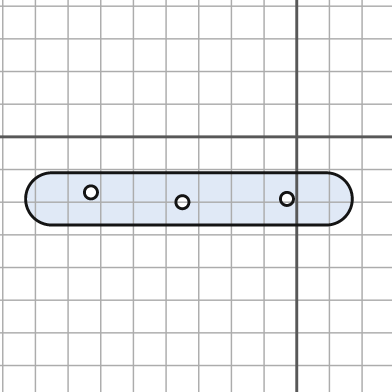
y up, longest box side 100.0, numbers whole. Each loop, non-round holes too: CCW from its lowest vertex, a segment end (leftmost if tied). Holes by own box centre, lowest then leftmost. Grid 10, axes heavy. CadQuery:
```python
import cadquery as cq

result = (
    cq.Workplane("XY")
    .moveTo(-75.0, -27.0)
    .lineTo(9.0, -27.0)
    .threePointArc((17.0, -19.0), (9.0, -11.0))
    .lineTo(-75.0, -11.0)
    .threePointArc((-83.0, -19.0), (-75.0, -27.0))
    .close()
    .moveTo(-35.0, -20.0)
    .circle(2.0)
    .moveTo(-3.0, -19.0)
    .circle(2.0)
    .moveTo(-63.0, -17.0)
    .circle(2.0)
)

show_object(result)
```